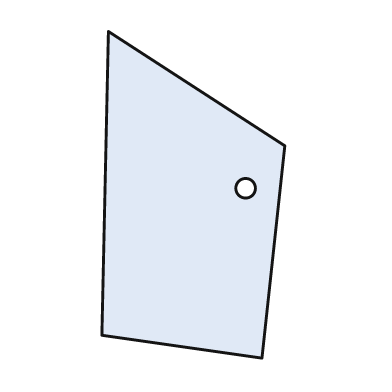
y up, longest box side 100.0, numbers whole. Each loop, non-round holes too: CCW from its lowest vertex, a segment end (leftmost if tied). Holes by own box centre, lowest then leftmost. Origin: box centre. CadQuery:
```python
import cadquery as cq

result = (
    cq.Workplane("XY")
    .moveTo(21.0, -50.0)
    .lineTo(28.0, 15.0)
    .lineTo(-26.0, 50.0)
    .lineTo(-28.0, -43.0)
    .close()
    .moveTo(16.0, 2.0)
    .circle(3.0)
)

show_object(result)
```